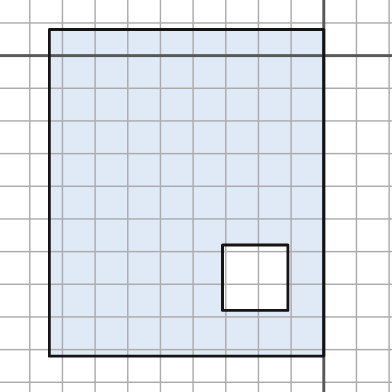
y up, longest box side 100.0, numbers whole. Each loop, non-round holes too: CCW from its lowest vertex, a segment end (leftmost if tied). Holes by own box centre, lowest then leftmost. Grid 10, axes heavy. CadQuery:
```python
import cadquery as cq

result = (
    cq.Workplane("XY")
    .moveTo(-84.0, -92.0)
    .lineTo(0.0, -92.0)
    .lineTo(0.0, 8.0)
    .lineTo(-84.0, 8.0)
    .close()
    .moveTo(-31.0, -78.0)
    .lineTo(-11.0, -78.0)
    .lineTo(-11.0, -58.0)
    .lineTo(-31.0, -58.0)
    .close()
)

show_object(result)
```